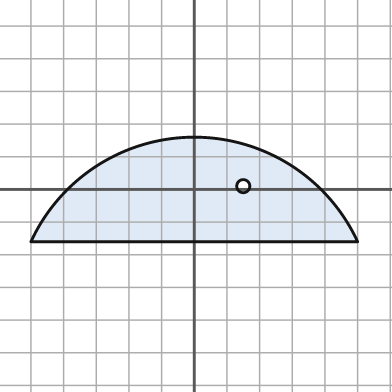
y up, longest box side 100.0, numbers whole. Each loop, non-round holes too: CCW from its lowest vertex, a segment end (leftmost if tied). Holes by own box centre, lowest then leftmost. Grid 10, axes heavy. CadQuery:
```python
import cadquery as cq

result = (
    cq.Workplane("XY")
    .moveTo(-50.0, -16.0)
    .lineTo(50.0, -16.0)
    .threePointArc((0.0, 16.0), (-50.0, -16.0))
    .close()
    .moveTo(15.0, 1.0)
    .circle(2.0)
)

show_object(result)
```